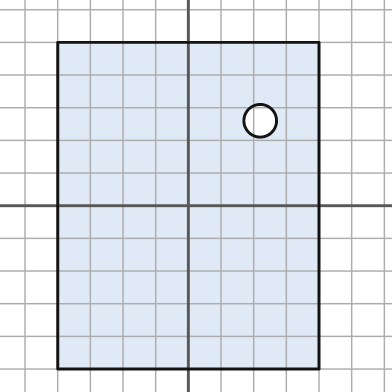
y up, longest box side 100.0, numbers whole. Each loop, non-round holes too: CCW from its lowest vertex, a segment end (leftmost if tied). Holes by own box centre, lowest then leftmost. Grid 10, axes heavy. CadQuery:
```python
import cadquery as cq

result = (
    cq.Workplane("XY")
    .moveTo(-40.0, -50.0)
    .lineTo(40.0, -50.0)
    .lineTo(40.0, 50.0)
    .lineTo(-40.0, 50.0)
    .close()
    .moveTo(22.0, 26.0)
    .circle(5.0)
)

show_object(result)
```